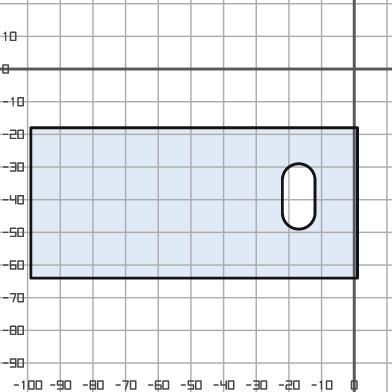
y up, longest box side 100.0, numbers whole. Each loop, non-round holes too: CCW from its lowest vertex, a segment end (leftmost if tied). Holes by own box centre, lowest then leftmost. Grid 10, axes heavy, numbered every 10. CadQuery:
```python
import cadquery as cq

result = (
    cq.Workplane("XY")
    .moveTo(-99.0, -64.0)
    .lineTo(1.0, -64.0)
    .lineTo(1.0, -18.0)
    .lineTo(-99.0, -18.0)
    .close()
    .moveTo(-22.0, -44.0)
    .threePointArc((-17.0, -49.0), (-12.0, -44.0))
    .lineTo(-12.0, -34.0)
    .threePointArc((-17.0, -29.0), (-22.0, -34.0))
    .close()
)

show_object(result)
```